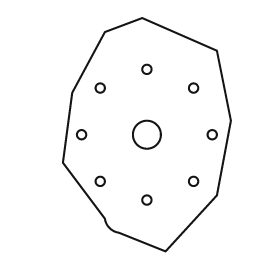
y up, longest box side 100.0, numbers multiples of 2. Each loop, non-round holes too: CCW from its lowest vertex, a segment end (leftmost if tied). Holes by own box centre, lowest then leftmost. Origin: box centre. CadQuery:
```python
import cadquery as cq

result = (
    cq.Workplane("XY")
    .moveTo(8.0, -50.0)
    .lineTo(30.0, -26.0)
    .lineTo(36.0, 6.0)
    .lineTo(30.0, 36.0)
    .lineTo(-2.0, 50.0)
    .lineTo(-18.0, 44.0)
    .lineTo(-32.0, 18.0)
    .lineTo(-36.0, -12.0)
    .lineTo(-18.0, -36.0)
    .threePointArc((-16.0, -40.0), (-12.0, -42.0))
    .close()
    .moveTo(0.0, -28.0)
    .circle(2.0)
    .moveTo(-20.0, -20.0)
    .circle(2.0)
    .moveTo(20.0, -20.0)
    .circle(2.0)
    .moveTo(-28.0, 0.0)
    .circle(2.0)
    .moveTo(0.0, 0.0)
    .circle(6.0)
    .moveTo(28.0, 0.0)
    .circle(2.0)
    .moveTo(-20.0, 20.0)
    .circle(2.0)
    .moveTo(20.0, 20.0)
    .circle(2.0)
    .moveTo(0.0, 28.0)
    .circle(2.0)
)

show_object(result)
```